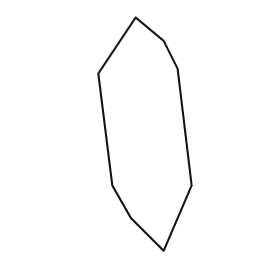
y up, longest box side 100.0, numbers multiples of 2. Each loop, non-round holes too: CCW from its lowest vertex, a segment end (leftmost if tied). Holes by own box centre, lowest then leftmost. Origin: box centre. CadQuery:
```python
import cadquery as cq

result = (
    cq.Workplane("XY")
    .moveTo(8.0, -50.0)
    .lineTo(20.0, -22.0)
    .lineTo(14.0, 28.0)
    .lineTo(8.0, 40.0)
    .lineTo(-4.0, 50.0)
    .lineTo(-20.0, 26.0)
    .lineTo(-14.0, -22.0)
    .lineTo(-6.0, -36.0)
    .close()
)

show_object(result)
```